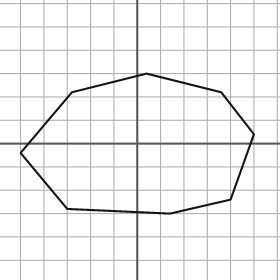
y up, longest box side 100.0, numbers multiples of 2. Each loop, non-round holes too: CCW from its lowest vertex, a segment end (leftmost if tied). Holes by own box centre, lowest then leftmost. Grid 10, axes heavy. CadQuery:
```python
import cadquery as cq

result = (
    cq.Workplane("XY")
    .moveTo(14.0, -30.0)
    .lineTo(40.0, -24.0)
    .lineTo(50.0, 4.0)
    .lineTo(36.0, 22.0)
    .lineTo(4.0, 30.0)
    .lineTo(-28.0, 22.0)
    .lineTo(-50.0, -4.0)
    .lineTo(-30.0, -28.0)
    .close()
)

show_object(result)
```